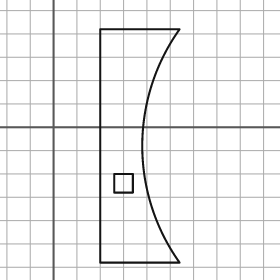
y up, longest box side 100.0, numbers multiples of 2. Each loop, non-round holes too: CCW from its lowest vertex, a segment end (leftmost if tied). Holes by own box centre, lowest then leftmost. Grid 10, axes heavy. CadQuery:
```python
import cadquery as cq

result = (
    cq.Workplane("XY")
    .moveTo(20.0, -58.0)
    .lineTo(54.0, -58.0)
    .threePointArc((38.0, -8.0), (54.0, 42.0))
    .lineTo(20.0, 42.0)
    .close()
    .moveTo(26.0, -28.0)
    .lineTo(34.0, -28.0)
    .lineTo(34.0, -20.0)
    .lineTo(26.0, -20.0)
    .close()
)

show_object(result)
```